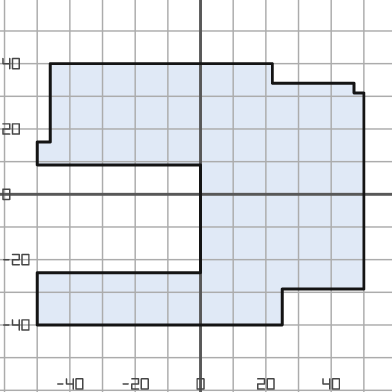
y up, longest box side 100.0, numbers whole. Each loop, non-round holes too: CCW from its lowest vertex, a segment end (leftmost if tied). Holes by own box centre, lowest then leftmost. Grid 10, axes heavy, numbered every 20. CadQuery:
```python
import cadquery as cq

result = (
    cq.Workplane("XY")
    .moveTo(-50.0, -40.0)
    .lineTo(25.0, -40.0)
    .lineTo(25.0, -29.0)
    .lineTo(50.0, -29.0)
    .lineTo(50.0, 31.0)
    .lineTo(47.0, 31.0)
    .lineTo(47.0, 34.0)
    .lineTo(22.0, 34.0)
    .lineTo(22.0, 40.0)
    .lineTo(-46.0, 40.0)
    .lineTo(-46.0, 16.0)
    .lineTo(-50.0, 16.0)
    .lineTo(-50.0, 9.0)
    .lineTo(0.0, 9.0)
    .lineTo(0.0, -24.0)
    .lineTo(-50.0, -24.0)
    .close()
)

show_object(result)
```